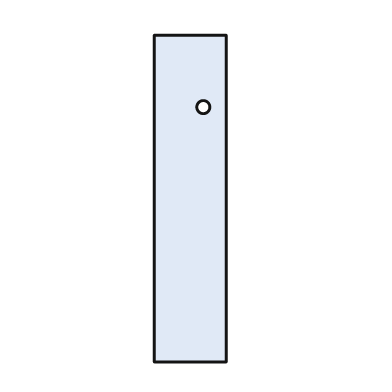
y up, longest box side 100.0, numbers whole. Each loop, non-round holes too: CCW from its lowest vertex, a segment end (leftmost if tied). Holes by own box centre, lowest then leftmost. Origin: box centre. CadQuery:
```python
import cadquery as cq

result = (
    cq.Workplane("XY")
    .moveTo(-11.0, -50.0)
    .lineTo(11.0, -50.0)
    .lineTo(11.0, 50.0)
    .lineTo(-11.0, 50.0)
    .close()
    .moveTo(4.0, 28.0)
    .circle(2.0)
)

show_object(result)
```